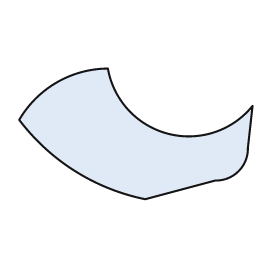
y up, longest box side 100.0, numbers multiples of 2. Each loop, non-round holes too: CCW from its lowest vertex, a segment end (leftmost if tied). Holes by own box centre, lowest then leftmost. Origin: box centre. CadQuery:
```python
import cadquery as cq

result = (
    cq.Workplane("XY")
    .moveTo(4.0, -28.0)
    .lineTo(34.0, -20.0)
    .threePointArc((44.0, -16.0), (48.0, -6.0))
    .lineTo(50.0, 12.0)
    .threePointArc((14.0, 0.0), (-12.0, 28.0))
    .threePointArc((-34.0, 22.0), (-50.0, 6.0))
    .threePointArc((-26.0, -16.0), (4.0, -28.0))
    .close()
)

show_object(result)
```